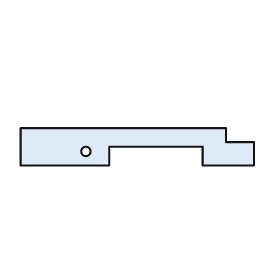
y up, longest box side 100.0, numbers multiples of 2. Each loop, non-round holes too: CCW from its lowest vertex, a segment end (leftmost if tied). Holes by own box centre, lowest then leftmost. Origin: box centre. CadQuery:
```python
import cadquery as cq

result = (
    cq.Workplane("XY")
    .moveTo(-50.0, -8.0)
    .lineTo(-12.0, -8.0)
    .lineTo(-12.0, 0.0)
    .lineTo(28.0, 0.0)
    .lineTo(28.0, -8.0)
    .lineTo(50.0, -8.0)
    .lineTo(50.0, 2.0)
    .lineTo(38.0, 2.0)
    .lineTo(38.0, 8.0)
    .lineTo(-50.0, 8.0)
    .close()
    .moveTo(-22.0, -2.0)
    .circle(2.0)
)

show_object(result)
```